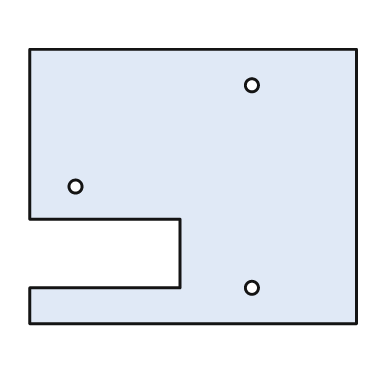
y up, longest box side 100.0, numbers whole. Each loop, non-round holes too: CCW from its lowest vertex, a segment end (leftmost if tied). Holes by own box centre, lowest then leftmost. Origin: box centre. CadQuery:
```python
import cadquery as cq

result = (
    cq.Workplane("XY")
    .moveTo(-50.0, -42.0)
    .lineTo(50.0, -42.0)
    .lineTo(50.0, 42.0)
    .lineTo(-50.0, 42.0)
    .lineTo(-50.0, -10.0)
    .lineTo(-4.0, -10.0)
    .lineTo(-4.0, -31.0)
    .lineTo(-50.0, -31.0)
    .close()
    .moveTo(18.0, -31.0)
    .circle(2.0)
    .moveTo(-36.0, 0.0)
    .circle(2.0)
    .moveTo(18.0, 31.0)
    .circle(2.0)
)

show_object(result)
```